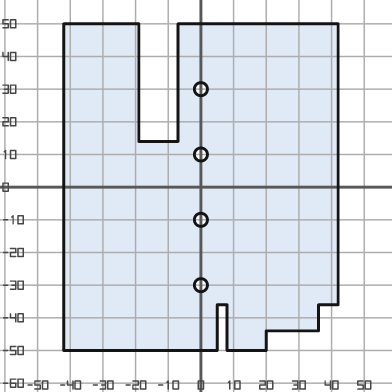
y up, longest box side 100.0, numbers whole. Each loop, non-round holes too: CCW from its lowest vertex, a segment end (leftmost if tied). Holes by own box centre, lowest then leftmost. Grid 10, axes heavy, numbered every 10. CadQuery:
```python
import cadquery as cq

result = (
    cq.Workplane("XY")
    .moveTo(-42.0, -50.0)
    .lineTo(5.0, -50.0)
    .lineTo(5.0, -36.0)
    .lineTo(8.0, -36.0)
    .lineTo(8.0, -50.0)
    .lineTo(20.0, -50.0)
    .lineTo(20.0, -44.0)
    .lineTo(36.0, -44.0)
    .lineTo(36.0, -36.0)
    .lineTo(42.0, -36.0)
    .lineTo(42.0, 50.0)
    .lineTo(-7.0, 50.0)
    .lineTo(-7.0, 14.0)
    .lineTo(-19.0, 14.0)
    .lineTo(-19.0, 50.0)
    .lineTo(-42.0, 50.0)
    .close()
    .moveTo(0.0, -30.0)
    .circle(2.0)
    .moveTo(0.0, -10.0)
    .circle(2.0)
    .moveTo(0.0, 10.0)
    .circle(2.0)
    .moveTo(0.0, 30.0)
    .circle(2.0)
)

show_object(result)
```